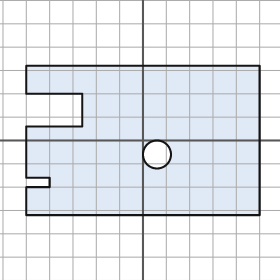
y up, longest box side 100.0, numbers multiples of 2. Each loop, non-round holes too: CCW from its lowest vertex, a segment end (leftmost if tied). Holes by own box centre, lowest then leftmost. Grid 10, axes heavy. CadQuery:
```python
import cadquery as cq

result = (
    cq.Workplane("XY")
    .moveTo(-50.0, -32.0)
    .lineTo(50.0, -32.0)
    .lineTo(50.0, 32.0)
    .lineTo(-50.0, 32.0)
    .lineTo(-50.0, 20.0)
    .lineTo(-26.0, 20.0)
    .lineTo(-26.0, 6.0)
    .lineTo(-50.0, 6.0)
    .lineTo(-50.0, -16.0)
    .lineTo(-40.0, -16.0)
    .lineTo(-40.0, -20.0)
    .lineTo(-50.0, -20.0)
    .close()
    .moveTo(6.0, -6.0)
    .circle(6.0)
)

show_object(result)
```